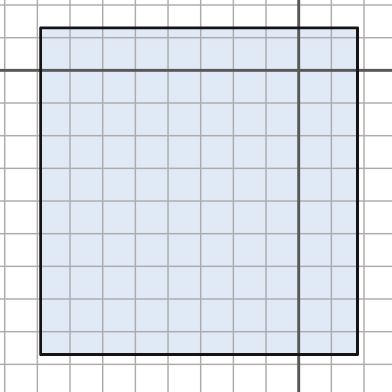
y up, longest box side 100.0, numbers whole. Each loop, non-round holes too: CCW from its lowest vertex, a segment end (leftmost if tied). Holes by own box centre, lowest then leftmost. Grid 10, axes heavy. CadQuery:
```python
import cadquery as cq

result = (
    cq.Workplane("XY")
    .moveTo(-79.0, -87.0)
    .lineTo(18.0, -87.0)
    .lineTo(18.0, 13.0)
    .lineTo(-79.0, 13.0)
    .close()
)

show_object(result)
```